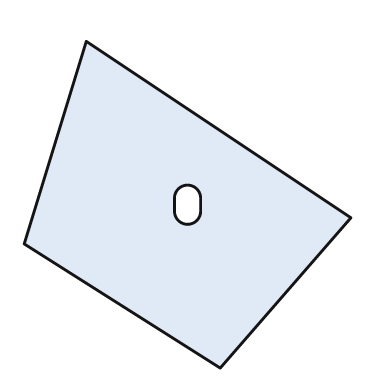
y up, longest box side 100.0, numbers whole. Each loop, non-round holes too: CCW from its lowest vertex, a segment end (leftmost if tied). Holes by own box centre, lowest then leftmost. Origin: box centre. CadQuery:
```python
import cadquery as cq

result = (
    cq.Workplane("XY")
    .moveTo(10.0, -50.0)
    .lineTo(50.0, -4.0)
    .lineTo(-31.0, 50.0)
    .lineTo(-50.0, -12.0)
    .close()
    .moveTo(-4.0, -2.0)
    .threePointArc((0.0, -6.0), (4.0, -2.0))
    .lineTo(4.0, 2.0)
    .threePointArc((0.0, 6.0), (-4.0, 2.0))
    .close()
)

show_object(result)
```